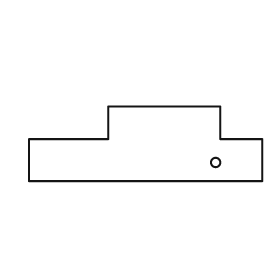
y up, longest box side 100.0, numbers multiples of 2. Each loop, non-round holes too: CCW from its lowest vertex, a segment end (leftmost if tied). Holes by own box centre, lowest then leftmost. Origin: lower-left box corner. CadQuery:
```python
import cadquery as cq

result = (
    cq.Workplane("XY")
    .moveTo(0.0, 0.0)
    .lineTo(100.0, 0.0)
    .lineTo(100.0, 18.0)
    .lineTo(82.0, 18.0)
    .lineTo(82.0, 32.0)
    .lineTo(34.0, 32.0)
    .lineTo(34.0, 18.0)
    .lineTo(0.0, 18.0)
    .close()
    .moveTo(80.0, 8.0)
    .circle(2.0)
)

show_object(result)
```